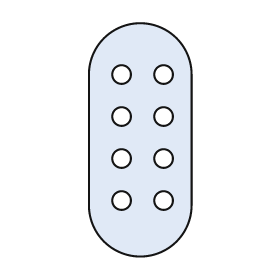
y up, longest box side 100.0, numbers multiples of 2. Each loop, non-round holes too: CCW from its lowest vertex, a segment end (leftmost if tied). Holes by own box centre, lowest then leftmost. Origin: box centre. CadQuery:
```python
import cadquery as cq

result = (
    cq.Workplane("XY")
    .moveTo(-22.0, -28.0)
    .threePointArc((0.0, -50.0), (22.0, -28.0))
    .lineTo(22.0, 28.0)
    .threePointArc((0.0, 50.0), (-22.0, 28.0))
    .close()
    .moveTo(-8.0, -26.0)
    .circle(4.0)
    .moveTo(10.0, -26.0)
    .circle(4.0)
    .moveTo(-8.0, -8.0)
    .circle(4.0)
    .moveTo(10.0, -8.0)
    .circle(4.0)
    .moveTo(-8.0, 10.0)
    .circle(4.0)
    .moveTo(10.0, 10.0)
    .circle(4.0)
    .moveTo(-8.0, 28.0)
    .circle(4.0)
    .moveTo(10.0, 28.0)
    .circle(4.0)
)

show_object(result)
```